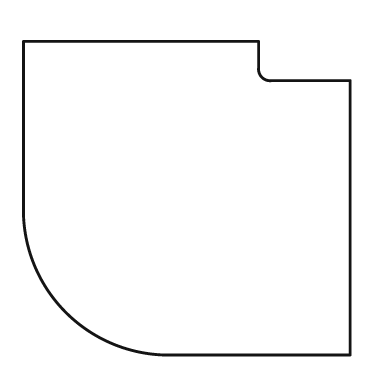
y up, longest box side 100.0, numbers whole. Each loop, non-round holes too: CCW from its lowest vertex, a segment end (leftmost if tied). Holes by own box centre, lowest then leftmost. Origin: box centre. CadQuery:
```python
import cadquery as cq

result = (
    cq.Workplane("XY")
    .moveTo(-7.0, -48.0)
    .lineTo(50.0, -48.0)
    .lineTo(50.0, 36.0)
    .lineTo(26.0, 36.0)
    .threePointArc((23.0, 37.0), (22.0, 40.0))
    .lineTo(22.0, 48.0)
    .lineTo(-50.0, 48.0)
    .lineTo(-50.0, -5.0)
    .threePointArc((-37.0, -35.0), (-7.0, -48.0))
    .close()
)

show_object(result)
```